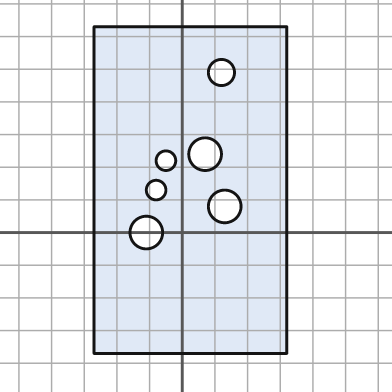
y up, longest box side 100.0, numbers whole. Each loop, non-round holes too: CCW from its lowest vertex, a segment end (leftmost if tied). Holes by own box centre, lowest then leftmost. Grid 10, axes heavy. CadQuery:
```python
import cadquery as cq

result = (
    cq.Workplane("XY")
    .moveTo(-27.0, -37.0)
    .lineTo(32.0, -37.0)
    .lineTo(32.0, 63.0)
    .lineTo(-27.0, 63.0)
    .close()
    .moveTo(-11.0, 0.0)
    .circle(5.0)
    .moveTo(13.0, 8.0)
    .circle(5.0)
    .moveTo(-8.0, 13.0)
    .circle(3.0)
    .moveTo(-5.0, 22.0)
    .circle(3.0)
    .moveTo(7.0, 24.0)
    .circle(5.0)
    .moveTo(12.0, 49.0)
    .circle(4.0)
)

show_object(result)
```